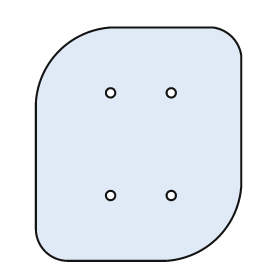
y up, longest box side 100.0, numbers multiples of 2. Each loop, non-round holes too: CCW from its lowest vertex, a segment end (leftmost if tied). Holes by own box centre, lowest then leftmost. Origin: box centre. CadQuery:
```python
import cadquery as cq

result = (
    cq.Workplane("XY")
    .moveTo(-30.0, -50.0)
    .lineTo(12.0, -50.0)
    .threePointArc((34.0, -40.0), (44.0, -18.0))
    .lineTo(44.0, 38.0)
    .threePointArc((40.0, 46.0), (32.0, 50.0))
    .lineTo(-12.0, 50.0)
    .threePointArc((-34.0, 40.0), (-44.0, 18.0))
    .lineTo(-44.0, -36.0)
    .threePointArc((-40.0, -46.0), (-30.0, -50.0))
    .close()
    .moveTo(-12.0, -22.0)
    .circle(2.0)
    .moveTo(14.0, -22.0)
    .circle(2.0)
    .moveTo(-12.0, 22.0)
    .circle(2.0)
    .moveTo(14.0, 22.0)
    .circle(2.0)
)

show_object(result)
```